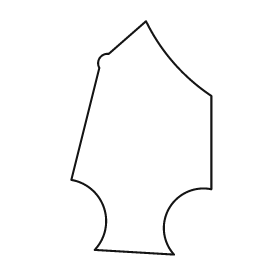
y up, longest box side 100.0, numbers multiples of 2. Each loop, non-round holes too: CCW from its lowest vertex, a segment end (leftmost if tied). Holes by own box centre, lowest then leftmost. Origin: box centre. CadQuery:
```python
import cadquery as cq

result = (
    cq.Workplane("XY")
    .moveTo(14.0, -50.0)
    .threePointArc((12.0, -30.0), (30.0, -22.0))
    .lineTo(30.0, 18.0)
    .threePointArc((14.0, 32.0), (2.0, 50.0))
    .lineTo(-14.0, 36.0)
    .threePointArc((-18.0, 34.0), (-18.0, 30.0))
    .lineTo(-30.0, -18.0)
    .threePointArc((-16.0, -30.0), (-20.0, -48.0))
    .close()
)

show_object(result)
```